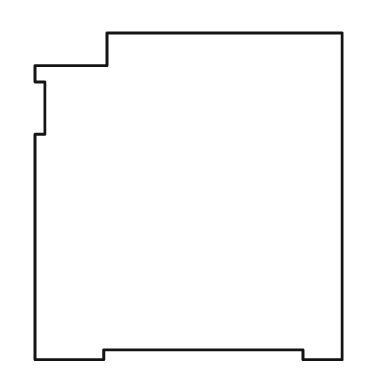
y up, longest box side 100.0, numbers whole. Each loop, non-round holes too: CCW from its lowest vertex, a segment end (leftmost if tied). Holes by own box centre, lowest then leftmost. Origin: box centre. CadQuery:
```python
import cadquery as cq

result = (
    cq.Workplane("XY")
    .moveTo(-47.0, -50.0)
    .lineTo(-26.0, -50.0)
    .lineTo(-26.0, -47.0)
    .lineTo(35.0, -47.0)
    .lineTo(35.0, -50.0)
    .lineTo(47.0, -50.0)
    .lineTo(47.0, 50.0)
    .lineTo(-25.0, 50.0)
    .lineTo(-25.0, 40.0)
    .lineTo(-47.0, 40.0)
    .lineTo(-47.0, 35.0)
    .lineTo(-44.0, 35.0)
    .lineTo(-44.0, 19.0)
    .lineTo(-47.0, 19.0)
    .close()
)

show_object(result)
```